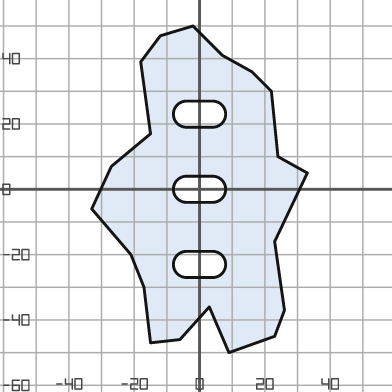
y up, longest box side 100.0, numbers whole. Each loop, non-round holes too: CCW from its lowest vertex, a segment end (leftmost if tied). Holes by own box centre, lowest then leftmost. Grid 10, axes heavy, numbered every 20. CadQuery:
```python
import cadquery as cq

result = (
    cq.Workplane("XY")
    .moveTo(9.0, -50.0)
    .lineTo(23.0, -45.0)
    .lineTo(26.0, -37.0)
    .lineTo(23.0, -16.0)
    .lineTo(33.0, 5.0)
    .lineTo(24.0, 10.0)
    .lineTo(22.0, 30.0)
    .lineTo(16.0, 36.0)
    .lineTo(7.0, 41.0)
    .lineTo(-2.0, 50.0)
    .lineTo(-12.0, 47.0)
    .lineTo(-18.0, 39.0)
    .lineTo(-15.0, 17.0)
    .lineTo(-27.0, 7.0)
    .lineTo(-33.0, -6.0)
    .lineTo(-21.0, -20.0)
    .lineTo(-17.0, -30.0)
    .lineTo(-15.0, -47.0)
    .lineTo(-6.0, -46.0)
    .lineTo(3.0, -36.0)
    .close()
    .moveTo(-4.0, -27.0)
    .lineTo(4.0, -27.0)
    .threePointArc((8.0, -23.0), (4.0, -19.0))
    .lineTo(-4.0, -19.0)
    .threePointArc((-8.0, -23.0), (-4.0, -27.0))
    .close()
    .moveTo(-4.0, -4.0)
    .lineTo(4.0, -4.0)
    .threePointArc((8.0, 0.0), (4.0, 4.0))
    .lineTo(-4.0, 4.0)
    .threePointArc((-8.0, 0.0), (-4.0, -4.0))
    .close()
    .moveTo(-4.0, 19.0)
    .lineTo(4.0, 19.0)
    .threePointArc((8.0, 23.0), (4.0, 27.0))
    .lineTo(-4.0, 27.0)
    .threePointArc((-8.0, 23.0), (-4.0, 19.0))
    .close()
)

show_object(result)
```